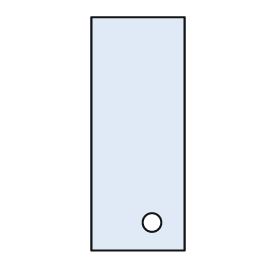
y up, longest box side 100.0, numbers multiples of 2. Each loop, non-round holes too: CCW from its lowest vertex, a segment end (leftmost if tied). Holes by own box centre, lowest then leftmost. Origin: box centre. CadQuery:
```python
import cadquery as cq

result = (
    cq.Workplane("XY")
    .moveTo(-20.0, -50.0)
    .lineTo(20.0, -50.0)
    .lineTo(20.0, 50.0)
    .lineTo(-20.0, 50.0)
    .close()
    .moveTo(6.0, -38.0)
    .circle(4.0)
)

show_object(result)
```